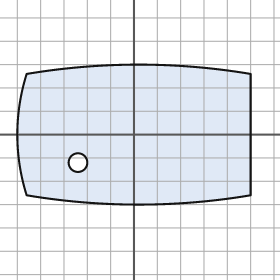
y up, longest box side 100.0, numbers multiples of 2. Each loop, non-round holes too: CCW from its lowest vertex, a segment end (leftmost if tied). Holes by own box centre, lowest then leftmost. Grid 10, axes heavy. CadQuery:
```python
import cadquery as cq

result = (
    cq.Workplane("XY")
    .moveTo(-46.0, -26.0)
    .threePointArc((2.0, -30.0), (50.0, -26.0))
    .lineTo(50.0, 26.0)
    .threePointArc((2.0, 30.0), (-46.0, 26.0))
    .threePointArc((-50.0, 0.0), (-46.0, -26.0))
    .close()
    .moveTo(-24.0, -12.0)
    .circle(4.0)
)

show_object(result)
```